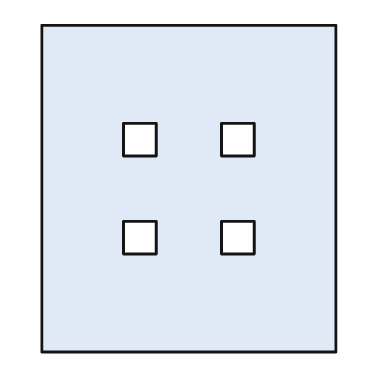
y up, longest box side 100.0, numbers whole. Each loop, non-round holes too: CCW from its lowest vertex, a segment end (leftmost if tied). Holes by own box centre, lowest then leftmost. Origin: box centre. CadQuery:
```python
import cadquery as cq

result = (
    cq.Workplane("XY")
    .moveTo(-45.0, -50.0)
    .lineTo(45.0, -50.0)
    .lineTo(45.0, 50.0)
    .lineTo(-45.0, 50.0)
    .close()
    .moveTo(-20.0, -20.0)
    .lineTo(-10.0, -20.0)
    .lineTo(-10.0, -10.0)
    .lineTo(-20.0, -10.0)
    .close()
    .moveTo(10.0, -20.0)
    .lineTo(20.0, -20.0)
    .lineTo(20.0, -10.0)
    .lineTo(10.0, -10.0)
    .close()
    .moveTo(-20.0, 10.0)
    .lineTo(-10.0, 10.0)
    .lineTo(-10.0, 20.0)
    .lineTo(-20.0, 20.0)
    .close()
    .moveTo(10.0, 10.0)
    .lineTo(20.0, 10.0)
    .lineTo(20.0, 20.0)
    .lineTo(10.0, 20.0)
    .close()
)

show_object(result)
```